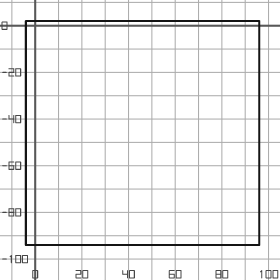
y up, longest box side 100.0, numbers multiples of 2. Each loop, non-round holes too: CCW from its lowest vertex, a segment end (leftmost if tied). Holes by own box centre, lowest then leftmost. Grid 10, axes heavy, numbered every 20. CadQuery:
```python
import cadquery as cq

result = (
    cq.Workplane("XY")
    .moveTo(-4.0, -94.0)
    .lineTo(96.0, -94.0)
    .lineTo(96.0, 2.0)
    .lineTo(-4.0, 2.0)
    .close()
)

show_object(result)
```